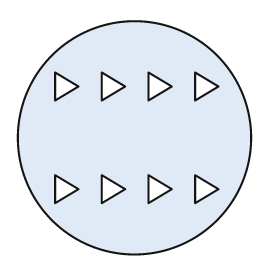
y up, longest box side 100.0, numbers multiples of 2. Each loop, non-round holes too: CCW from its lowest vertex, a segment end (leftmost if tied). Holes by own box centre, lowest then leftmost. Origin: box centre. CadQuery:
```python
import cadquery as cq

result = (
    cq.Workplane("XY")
    .moveTo(0.0, 0.0)
    .circle(50.0)
    .moveTo(-34.0, -28.0)
    .lineTo(-24.0, -22.0)
    .lineTo(-34.0, -16.0)
    .close()
    .moveTo(-14.0, -28.0)
    .lineTo(-4.0, -22.0)
    .lineTo(-14.0, -16.0)
    .close()
    .moveTo(6.0, -28.0)
    .lineTo(16.0, -22.0)
    .lineTo(6.0, -16.0)
    .close()
    .moveTo(26.0, -28.0)
    .lineTo(36.0, -22.0)
    .lineTo(26.0, -16.0)
    .close()
    .moveTo(-34.0, 16.0)
    .lineTo(-24.0, 22.0)
    .lineTo(-34.0, 28.0)
    .close()
    .moveTo(-14.0, 16.0)
    .lineTo(-4.0, 22.0)
    .lineTo(-14.0, 28.0)
    .close()
    .moveTo(6.0, 16.0)
    .lineTo(16.0, 22.0)
    .lineTo(6.0, 28.0)
    .close()
    .moveTo(26.0, 16.0)
    .lineTo(36.0, 22.0)
    .lineTo(26.0, 28.0)
    .close()
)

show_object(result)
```